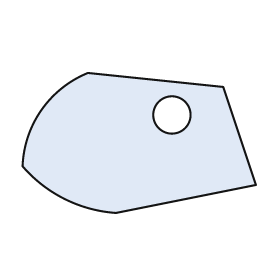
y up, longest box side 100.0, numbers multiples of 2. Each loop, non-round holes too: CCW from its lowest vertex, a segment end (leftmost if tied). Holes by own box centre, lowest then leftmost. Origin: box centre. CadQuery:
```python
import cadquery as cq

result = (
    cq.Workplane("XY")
    .moveTo(-10.0, -30.0)
    .lineTo(50.0, -18.0)
    .lineTo(36.0, 24.0)
    .lineTo(-22.0, 30.0)
    .threePointArc((-42.0, 14.0), (-50.0, -10.0))
    .threePointArc((-32.0, -24.0), (-10.0, -30.0))
    .close()
    .moveTo(14.0, 12.0)
    .circle(8.0)
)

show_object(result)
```